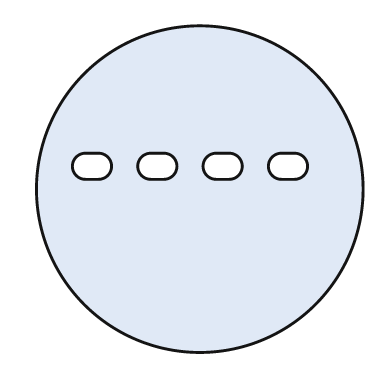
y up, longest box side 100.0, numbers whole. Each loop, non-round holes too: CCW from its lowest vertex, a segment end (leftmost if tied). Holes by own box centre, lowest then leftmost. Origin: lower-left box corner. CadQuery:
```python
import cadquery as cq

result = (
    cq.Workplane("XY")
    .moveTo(50.0, 50.0)
    .circle(50.0)
    .moveTo(15.0, 53.0)
    .lineTo(19.0, 53.0)
    .threePointArc((23.0, 57.0), (19.0, 61.0))
    .lineTo(15.0, 61.0)
    .threePointArc((11.0, 57.0), (15.0, 53.0))
    .close()
    .moveTo(35.0, 53.0)
    .lineTo(39.0, 53.0)
    .threePointArc((43.0, 57.0), (39.0, 61.0))
    .lineTo(35.0, 61.0)
    .threePointArc((31.0, 57.0), (35.0, 53.0))
    .close()
    .moveTo(55.0, 53.0)
    .lineTo(59.0, 53.0)
    .threePointArc((63.0, 57.0), (59.0, 61.0))
    .lineTo(55.0, 61.0)
    .threePointArc((51.0, 57.0), (55.0, 53.0))
    .close()
    .moveTo(75.0, 53.0)
    .lineTo(79.0, 53.0)
    .threePointArc((83.0, 57.0), (79.0, 61.0))
    .lineTo(75.0, 61.0)
    .threePointArc((71.0, 57.0), (75.0, 53.0))
    .close()
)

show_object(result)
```